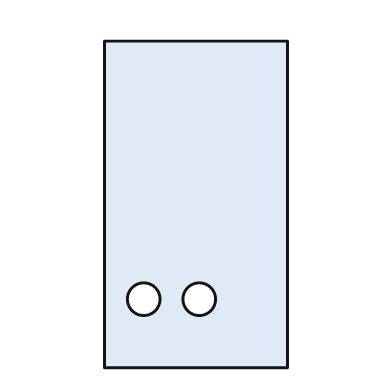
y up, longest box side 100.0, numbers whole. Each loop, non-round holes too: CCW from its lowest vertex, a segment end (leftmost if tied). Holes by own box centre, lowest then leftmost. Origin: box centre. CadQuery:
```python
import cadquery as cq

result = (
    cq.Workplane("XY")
    .moveTo(-28.0, -50.0)
    .lineTo(28.0, -50.0)
    .lineTo(28.0, 50.0)
    .lineTo(-28.0, 50.0)
    .close()
    .moveTo(-16.0, -29.0)
    .circle(5.0)
    .moveTo(1.0, -29.0)
    .circle(5.0)
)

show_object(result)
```